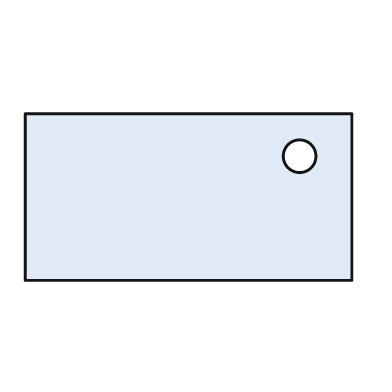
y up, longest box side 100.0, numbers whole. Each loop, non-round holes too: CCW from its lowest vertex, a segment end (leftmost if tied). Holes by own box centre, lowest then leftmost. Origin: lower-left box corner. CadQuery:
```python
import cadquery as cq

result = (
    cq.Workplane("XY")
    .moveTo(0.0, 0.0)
    .lineTo(100.0, 0.0)
    .lineTo(100.0, 51.0)
    .lineTo(0.0, 51.0)
    .close()
    .moveTo(84.0, 38.0)
    .circle(5.0)
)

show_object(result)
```